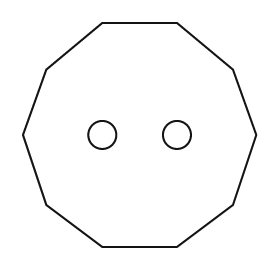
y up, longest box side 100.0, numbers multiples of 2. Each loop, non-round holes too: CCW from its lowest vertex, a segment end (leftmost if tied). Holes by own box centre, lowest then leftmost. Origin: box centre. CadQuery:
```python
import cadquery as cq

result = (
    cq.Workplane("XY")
    .moveTo(-16.0, -48.0)
    .lineTo(16.0, -48.0)
    .lineTo(40.0, -30.0)
    .lineTo(50.0, 0.0)
    .lineTo(40.0, 28.0)
    .lineTo(16.0, 48.0)
    .lineTo(-16.0, 48.0)
    .lineTo(-40.0, 28.0)
    .lineTo(-50.0, 0.0)
    .lineTo(-40.0, -30.0)
    .close()
    .moveTo(-16.0, 0.0)
    .circle(6.0)
    .moveTo(16.0, 0.0)
    .circle(6.0)
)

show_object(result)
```